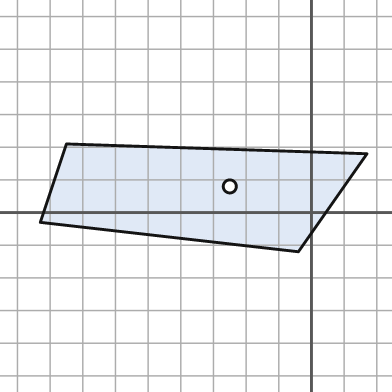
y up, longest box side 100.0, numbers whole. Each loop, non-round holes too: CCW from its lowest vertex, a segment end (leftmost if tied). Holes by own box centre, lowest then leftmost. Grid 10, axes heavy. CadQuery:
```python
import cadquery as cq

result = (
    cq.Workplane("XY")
    .moveTo(-4.0, -12.0)
    .lineTo(17.0, 18.0)
    .lineTo(-75.0, 21.0)
    .lineTo(-83.0, -3.0)
    .close()
    .moveTo(-25.0, 8.0)
    .circle(2.0)
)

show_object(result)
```